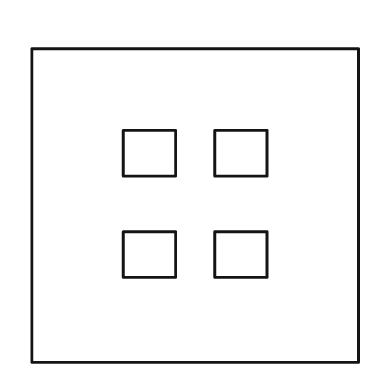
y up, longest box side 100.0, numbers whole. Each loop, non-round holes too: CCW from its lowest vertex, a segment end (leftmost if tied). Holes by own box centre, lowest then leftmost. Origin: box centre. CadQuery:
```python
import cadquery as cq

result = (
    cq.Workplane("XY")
    .moveTo(-50.0, -48.0)
    .lineTo(50.0, -48.0)
    .lineTo(50.0, 48.0)
    .lineTo(-50.0, 48.0)
    .close()
    .moveTo(-22.0, -22.0)
    .lineTo(-6.0, -22.0)
    .lineTo(-6.0, -8.0)
    .lineTo(-22.0, -8.0)
    .close()
    .moveTo(6.0, -22.0)
    .lineTo(22.0, -22.0)
    .lineTo(22.0, -8.0)
    .lineTo(6.0, -8.0)
    .close()
    .moveTo(-22.0, 9.0)
    .lineTo(-6.0, 9.0)
    .lineTo(-6.0, 23.0)
    .lineTo(-22.0, 23.0)
    .close()
    .moveTo(6.0, 9.0)
    .lineTo(22.0, 9.0)
    .lineTo(22.0, 23.0)
    .lineTo(6.0, 23.0)
    .close()
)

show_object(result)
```